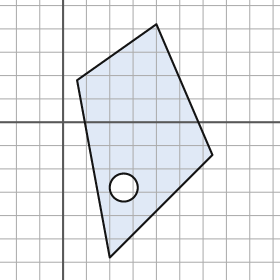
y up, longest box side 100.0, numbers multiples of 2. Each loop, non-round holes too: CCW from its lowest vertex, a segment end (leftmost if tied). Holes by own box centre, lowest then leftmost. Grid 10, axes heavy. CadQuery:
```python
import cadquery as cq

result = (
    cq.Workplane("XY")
    .moveTo(20.0, -58.0)
    .lineTo(64.0, -14.0)
    .lineTo(40.0, 42.0)
    .lineTo(6.0, 18.0)
    .close()
    .moveTo(26.0, -28.0)
    .circle(6.0)
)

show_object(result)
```